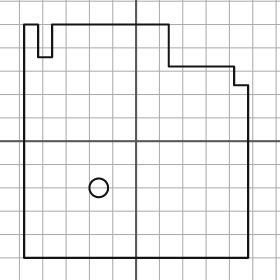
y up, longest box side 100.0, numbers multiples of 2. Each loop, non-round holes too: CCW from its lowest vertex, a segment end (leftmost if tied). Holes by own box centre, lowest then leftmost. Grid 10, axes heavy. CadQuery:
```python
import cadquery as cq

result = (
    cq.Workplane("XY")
    .moveTo(-48.0, -50.0)
    .lineTo(48.0, -50.0)
    .lineTo(48.0, 24.0)
    .lineTo(42.0, 24.0)
    .lineTo(42.0, 32.0)
    .lineTo(14.0, 32.0)
    .lineTo(14.0, 50.0)
    .lineTo(-36.0, 50.0)
    .lineTo(-36.0, 36.0)
    .lineTo(-42.0, 36.0)
    .lineTo(-42.0, 50.0)
    .lineTo(-48.0, 50.0)
    .close()
    .moveTo(-16.0, -20.0)
    .circle(4.0)
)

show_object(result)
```